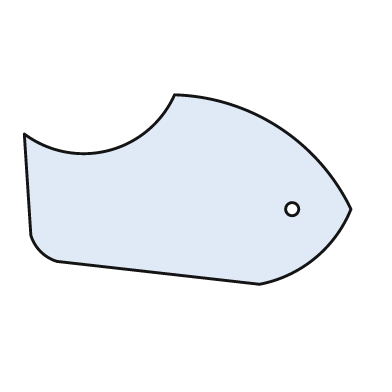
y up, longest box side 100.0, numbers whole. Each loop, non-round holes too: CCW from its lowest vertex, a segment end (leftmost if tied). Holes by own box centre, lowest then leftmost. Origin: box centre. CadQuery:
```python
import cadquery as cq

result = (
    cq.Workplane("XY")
    .moveTo(22.0, -29.0)
    .threePointArc((39.0, -21.0), (50.0, -6.0))
    .threePointArc((28.0, 19.0), (-4.0, 29.0))
    .threePointArc((-24.0, 12.0), (-50.0, 17.0))
    .lineTo(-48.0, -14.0)
    .threePointArc((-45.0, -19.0), (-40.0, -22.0))
    .close()
    .moveTo(32.0, -6.0)
    .circle(2.0)
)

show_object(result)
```